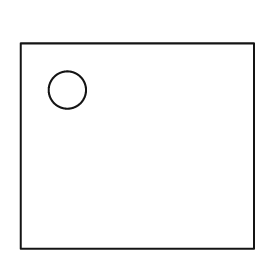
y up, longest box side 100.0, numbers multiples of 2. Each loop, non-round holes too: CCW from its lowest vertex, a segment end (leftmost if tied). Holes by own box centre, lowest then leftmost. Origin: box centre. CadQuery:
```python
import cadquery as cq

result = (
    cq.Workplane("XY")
    .moveTo(-50.0, -44.0)
    .lineTo(50.0, -44.0)
    .lineTo(50.0, 44.0)
    .lineTo(-50.0, 44.0)
    .close()
    .moveTo(-30.0, 24.0)
    .circle(8.0)
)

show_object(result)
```